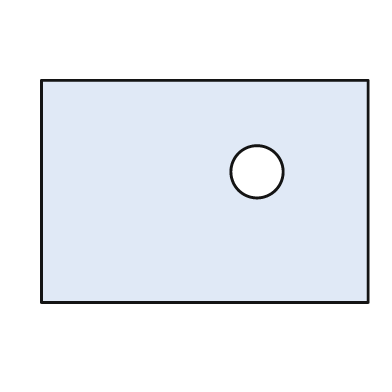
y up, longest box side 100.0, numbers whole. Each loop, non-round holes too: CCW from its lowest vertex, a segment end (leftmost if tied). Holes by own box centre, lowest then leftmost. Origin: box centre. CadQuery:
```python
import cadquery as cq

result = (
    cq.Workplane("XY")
    .moveTo(-50.0, -34.0)
    .lineTo(50.0, -34.0)
    .lineTo(50.0, 34.0)
    .lineTo(-50.0, 34.0)
    .close()
    .moveTo(16.0, 6.0)
    .circle(8.0)
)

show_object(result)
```